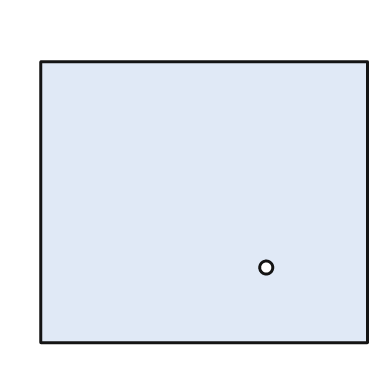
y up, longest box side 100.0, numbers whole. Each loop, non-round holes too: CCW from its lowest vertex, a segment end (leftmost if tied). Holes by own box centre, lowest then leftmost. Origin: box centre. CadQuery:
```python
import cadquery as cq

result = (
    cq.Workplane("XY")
    .moveTo(-50.0, -43.0)
    .lineTo(50.0, -43.0)
    .lineTo(50.0, 43.0)
    .lineTo(-50.0, 43.0)
    .close()
    .moveTo(19.0, -20.0)
    .circle(2.0)
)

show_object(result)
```